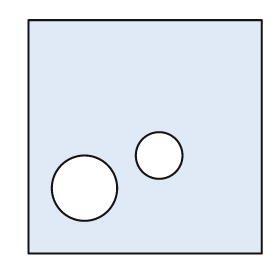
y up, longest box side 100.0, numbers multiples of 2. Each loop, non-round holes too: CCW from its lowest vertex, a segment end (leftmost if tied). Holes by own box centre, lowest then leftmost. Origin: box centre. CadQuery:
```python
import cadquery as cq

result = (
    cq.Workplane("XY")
    .moveTo(-50.0, -50.0)
    .lineTo(50.0, -50.0)
    .lineTo(50.0, 50.0)
    .lineTo(-50.0, 50.0)
    .close()
    .moveTo(-26.0, -22.0)
    .circle(14.0)
    .moveTo(6.0, -8.0)
    .circle(10.0)
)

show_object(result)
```